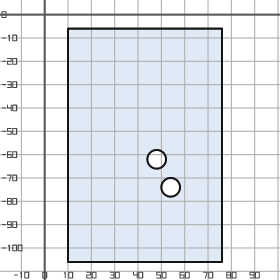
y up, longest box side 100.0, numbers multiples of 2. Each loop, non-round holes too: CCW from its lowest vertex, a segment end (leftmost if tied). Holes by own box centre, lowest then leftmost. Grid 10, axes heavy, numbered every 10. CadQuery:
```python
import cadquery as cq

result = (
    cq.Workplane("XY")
    .moveTo(10.0, -106.0)
    .lineTo(76.0, -106.0)
    .lineTo(76.0, -6.0)
    .lineTo(10.0, -6.0)
    .close()
    .moveTo(54.0, -74.0)
    .circle(4.0)
    .moveTo(48.0, -62.0)
    .circle(4.0)
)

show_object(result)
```